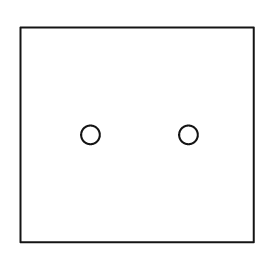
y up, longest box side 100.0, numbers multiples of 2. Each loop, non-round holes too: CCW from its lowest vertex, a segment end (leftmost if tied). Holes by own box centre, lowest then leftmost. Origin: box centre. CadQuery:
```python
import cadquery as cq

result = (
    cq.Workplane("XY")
    .moveTo(-50.0, -46.0)
    .lineTo(50.0, -46.0)
    .lineTo(50.0, 46.0)
    .lineTo(-50.0, 46.0)
    .close()
    .moveTo(-20.0, 0.0)
    .circle(4.0)
    .moveTo(22.0, 0.0)
    .circle(4.0)
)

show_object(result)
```